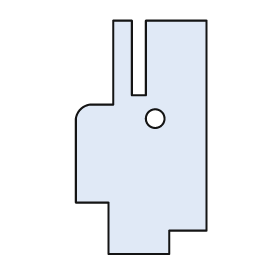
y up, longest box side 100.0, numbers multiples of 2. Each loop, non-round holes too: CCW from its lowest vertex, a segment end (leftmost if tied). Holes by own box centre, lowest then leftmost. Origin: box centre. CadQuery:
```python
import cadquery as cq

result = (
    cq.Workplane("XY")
    .moveTo(-14.0, -50.0)
    .lineTo(12.0, -50.0)
    .lineTo(12.0, -40.0)
    .lineTo(28.0, -40.0)
    .lineTo(28.0, 50.0)
    .lineTo(2.0, 50.0)
    .lineTo(2.0, 18.0)
    .lineTo(-4.0, 18.0)
    .lineTo(-4.0, 50.0)
    .lineTo(-12.0, 50.0)
    .lineTo(-12.0, 14.0)
    .lineTo(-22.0, 14.0)
    .threePointArc((-26.0, 12.0), (-28.0, 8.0))
    .lineTo(-28.0, -28.0)
    .lineTo(-14.0, -28.0)
    .close()
    .moveTo(6.0, 8.0)
    .circle(4.0)
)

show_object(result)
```